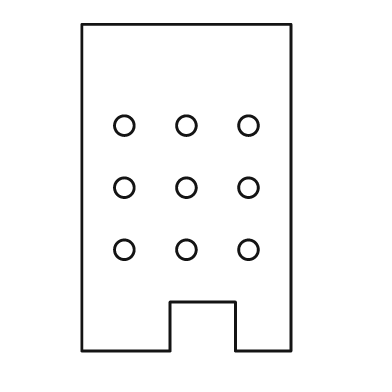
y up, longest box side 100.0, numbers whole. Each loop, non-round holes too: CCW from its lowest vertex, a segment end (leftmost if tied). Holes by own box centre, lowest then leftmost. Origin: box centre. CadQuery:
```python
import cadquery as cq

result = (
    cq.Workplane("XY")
    .moveTo(-32.0, -50.0)
    .lineTo(-5.0, -50.0)
    .lineTo(-5.0, -35.0)
    .lineTo(15.0, -35.0)
    .lineTo(15.0, -50.0)
    .lineTo(32.0, -50.0)
    .lineTo(32.0, 50.0)
    .lineTo(-32.0, 50.0)
    .close()
    .moveTo(-19.0, -19.0)
    .circle(3.0)
    .moveTo(0.0, -19.0)
    .circle(3.0)
    .moveTo(19.0, -19.0)
    .circle(3.0)
    .moveTo(-19.0, 0.0)
    .circle(3.0)
    .moveTo(0.0, 0.0)
    .circle(3.0)
    .moveTo(19.0, 0.0)
    .circle(3.0)
    .moveTo(-19.0, 19.0)
    .circle(3.0)
    .moveTo(0.0, 19.0)
    .circle(3.0)
    .moveTo(19.0, 19.0)
    .circle(3.0)
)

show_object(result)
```